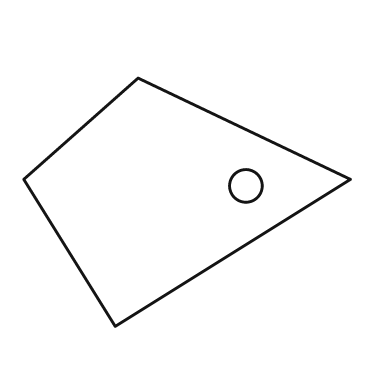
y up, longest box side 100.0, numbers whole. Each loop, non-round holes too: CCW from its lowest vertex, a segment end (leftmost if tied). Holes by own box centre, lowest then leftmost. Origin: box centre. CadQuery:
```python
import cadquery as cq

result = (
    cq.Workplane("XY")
    .moveTo(-22.0, -38.0)
    .lineTo(50.0, 7.0)
    .lineTo(-15.0, 38.0)
    .lineTo(-50.0, 7.0)
    .close()
    .moveTo(18.0, 5.0)
    .circle(5.0)
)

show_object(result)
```